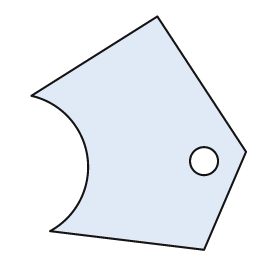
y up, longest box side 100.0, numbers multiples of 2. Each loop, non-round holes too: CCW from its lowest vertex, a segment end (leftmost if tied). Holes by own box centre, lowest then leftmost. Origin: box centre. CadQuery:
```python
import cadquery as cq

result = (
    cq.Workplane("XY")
    .moveTo(28.0, -50.0)
    .lineTo(46.0, -8.0)
    .lineTo(8.0, 50.0)
    .lineTo(-46.0, 16.0)
    .threePointArc((-22.0, -10.0), (-38.0, -42.0))
    .close()
    .moveTo(28.0, -12.0)
    .circle(6.0)
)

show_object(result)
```